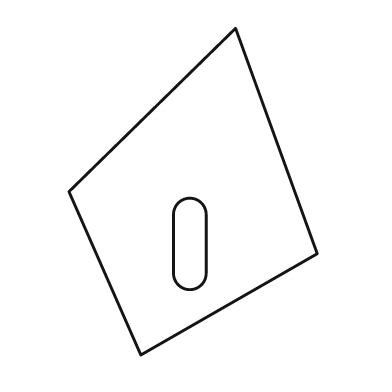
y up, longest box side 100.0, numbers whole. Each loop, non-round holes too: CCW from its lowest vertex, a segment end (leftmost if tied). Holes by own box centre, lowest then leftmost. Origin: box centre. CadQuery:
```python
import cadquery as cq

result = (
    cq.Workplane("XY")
    .moveTo(-16.0, -50.0)
    .lineTo(38.0, -19.0)
    .lineTo(13.0, 50.0)
    .lineTo(-38.0, 0.0)
    .close()
    .moveTo(-6.0, -25.0)
    .threePointArc((-1.0, -30.0), (4.0, -25.0))
    .lineTo(4.0, -7.0)
    .threePointArc((-1.0, -2.0), (-6.0, -7.0))
    .close()
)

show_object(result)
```